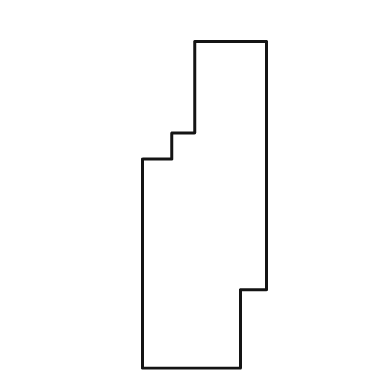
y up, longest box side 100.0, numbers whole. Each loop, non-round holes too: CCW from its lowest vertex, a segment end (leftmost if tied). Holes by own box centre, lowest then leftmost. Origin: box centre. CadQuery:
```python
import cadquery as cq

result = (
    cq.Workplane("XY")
    .moveTo(-19.0, -50.0)
    .lineTo(11.0, -50.0)
    .lineTo(11.0, -26.0)
    .lineTo(19.0, -26.0)
    .lineTo(19.0, 50.0)
    .lineTo(-3.0, 50.0)
    .lineTo(-3.0, 22.0)
    .lineTo(-10.0, 22.0)
    .lineTo(-10.0, 14.0)
    .lineTo(-19.0, 14.0)
    .close()
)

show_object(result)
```